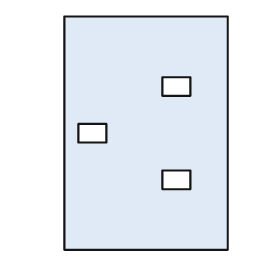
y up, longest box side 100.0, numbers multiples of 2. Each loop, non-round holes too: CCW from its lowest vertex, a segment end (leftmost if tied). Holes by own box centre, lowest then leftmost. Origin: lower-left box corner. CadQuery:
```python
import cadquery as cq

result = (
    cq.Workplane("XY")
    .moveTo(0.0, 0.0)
    .lineTo(70.0, 0.0)
    .lineTo(70.0, 100.0)
    .lineTo(0.0, 100.0)
    .close()
    .moveTo(42.0, 26.0)
    .lineTo(54.0, 26.0)
    .lineTo(54.0, 34.0)
    .lineTo(42.0, 34.0)
    .close()
    .moveTo(6.0, 46.0)
    .lineTo(18.0, 46.0)
    .lineTo(18.0, 54.0)
    .lineTo(6.0, 54.0)
    .close()
    .moveTo(42.0, 66.0)
    .lineTo(54.0, 66.0)
    .lineTo(54.0, 74.0)
    .lineTo(42.0, 74.0)
    .close()
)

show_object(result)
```